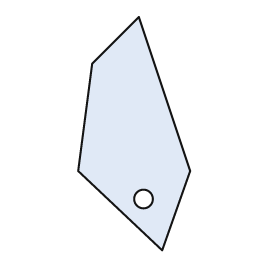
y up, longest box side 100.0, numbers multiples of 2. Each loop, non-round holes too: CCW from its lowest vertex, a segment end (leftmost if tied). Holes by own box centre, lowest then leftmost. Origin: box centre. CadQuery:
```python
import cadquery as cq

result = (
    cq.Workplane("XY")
    .moveTo(12.0, -50.0)
    .lineTo(24.0, -16.0)
    .lineTo(2.0, 50.0)
    .lineTo(-18.0, 30.0)
    .lineTo(-24.0, -16.0)
    .close()
    .moveTo(4.0, -28.0)
    .circle(4.0)
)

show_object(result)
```